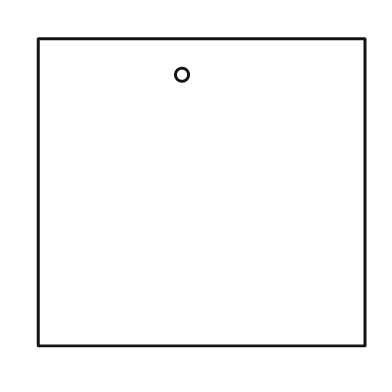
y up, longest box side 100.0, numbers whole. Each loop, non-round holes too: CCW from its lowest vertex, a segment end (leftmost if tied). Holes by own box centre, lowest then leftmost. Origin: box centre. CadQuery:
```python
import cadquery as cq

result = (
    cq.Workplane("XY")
    .moveTo(-50.0, -47.0)
    .lineTo(50.0, -47.0)
    .lineTo(50.0, 47.0)
    .lineTo(-50.0, 47.0)
    .close()
    .moveTo(-6.0, 36.0)
    .circle(2.0)
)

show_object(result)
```